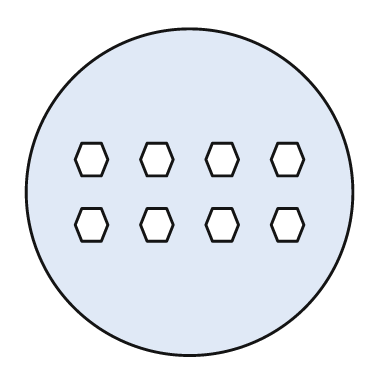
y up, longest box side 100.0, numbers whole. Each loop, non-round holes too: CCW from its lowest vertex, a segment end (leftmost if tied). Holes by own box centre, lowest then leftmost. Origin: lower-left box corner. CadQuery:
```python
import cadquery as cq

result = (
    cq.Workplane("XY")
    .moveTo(50.0, 50.0)
    .circle(50.0)
    .moveTo(17.0, 35.0)
    .lineTo(23.0, 35.0)
    .lineTo(25.0, 40.0)
    .lineTo(23.0, 45.0)
    .lineTo(17.0, 45.0)
    .lineTo(15.0, 40.0)
    .close()
    .moveTo(37.0, 35.0)
    .lineTo(43.0, 35.0)
    .lineTo(45.0, 40.0)
    .lineTo(43.0, 45.0)
    .lineTo(37.0, 45.0)
    .lineTo(35.0, 40.0)
    .close()
    .moveTo(57.0, 35.0)
    .lineTo(63.0, 35.0)
    .lineTo(65.0, 40.0)
    .lineTo(63.0, 45.0)
    .lineTo(57.0, 45.0)
    .lineTo(55.0, 40.0)
    .close()
    .moveTo(77.0, 35.0)
    .lineTo(83.0, 35.0)
    .lineTo(85.0, 40.0)
    .lineTo(83.0, 45.0)
    .lineTo(77.0, 45.0)
    .lineTo(75.0, 40.0)
    .close()
    .moveTo(17.0, 55.0)
    .lineTo(23.0, 55.0)
    .lineTo(25.0, 60.0)
    .lineTo(23.0, 65.0)
    .lineTo(17.0, 65.0)
    .lineTo(15.0, 60.0)
    .close()
    .moveTo(37.0, 55.0)
    .lineTo(43.0, 55.0)
    .lineTo(45.0, 60.0)
    .lineTo(43.0, 65.0)
    .lineTo(37.0, 65.0)
    .lineTo(35.0, 60.0)
    .close()
    .moveTo(57.0, 55.0)
    .lineTo(63.0, 55.0)
    .lineTo(65.0, 60.0)
    .lineTo(63.0, 65.0)
    .lineTo(57.0, 65.0)
    .lineTo(55.0, 60.0)
    .close()
    .moveTo(77.0, 55.0)
    .lineTo(83.0, 55.0)
    .lineTo(85.0, 60.0)
    .lineTo(83.0, 65.0)
    .lineTo(77.0, 65.0)
    .lineTo(75.0, 60.0)
    .close()
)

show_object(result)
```